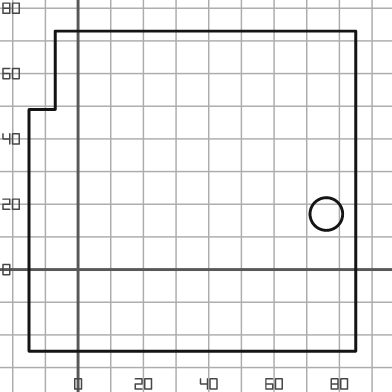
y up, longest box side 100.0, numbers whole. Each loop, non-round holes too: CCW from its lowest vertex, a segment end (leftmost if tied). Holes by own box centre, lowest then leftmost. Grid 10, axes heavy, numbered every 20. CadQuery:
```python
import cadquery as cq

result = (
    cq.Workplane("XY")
    .moveTo(-15.0, -25.0)
    .lineTo(85.0, -25.0)
    .lineTo(85.0, 73.0)
    .lineTo(-7.0, 73.0)
    .lineTo(-7.0, 49.0)
    .lineTo(-15.0, 49.0)
    .close()
    .moveTo(76.0, 17.0)
    .circle(5.0)
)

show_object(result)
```